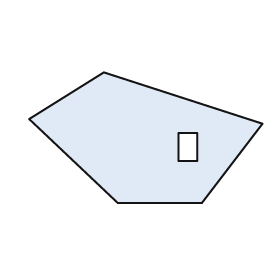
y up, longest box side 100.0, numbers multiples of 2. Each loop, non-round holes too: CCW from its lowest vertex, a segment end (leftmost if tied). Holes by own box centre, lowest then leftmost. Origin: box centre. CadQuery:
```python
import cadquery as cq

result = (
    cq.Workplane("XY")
    .moveTo(-12.0, -28.0)
    .lineTo(24.0, -28.0)
    .lineTo(50.0, 6.0)
    .lineTo(-18.0, 28.0)
    .lineTo(-50.0, 8.0)
    .close()
    .moveTo(14.0, -10.0)
    .lineTo(22.0, -10.0)
    .lineTo(22.0, 2.0)
    .lineTo(14.0, 2.0)
    .close()
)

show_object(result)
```